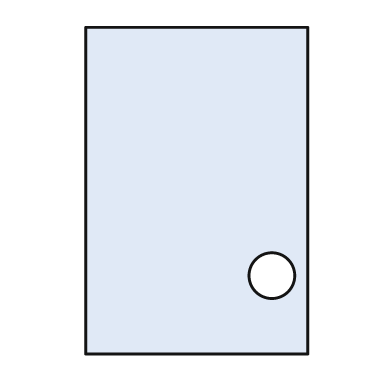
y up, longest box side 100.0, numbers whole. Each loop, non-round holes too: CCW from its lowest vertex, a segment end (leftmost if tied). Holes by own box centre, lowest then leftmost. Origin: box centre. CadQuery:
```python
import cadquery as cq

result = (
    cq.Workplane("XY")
    .moveTo(-34.0, -50.0)
    .lineTo(34.0, -50.0)
    .lineTo(34.0, 50.0)
    .lineTo(-34.0, 50.0)
    .close()
    .moveTo(23.0, -26.0)
    .circle(7.0)
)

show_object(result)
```